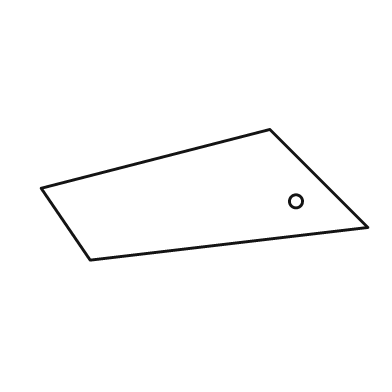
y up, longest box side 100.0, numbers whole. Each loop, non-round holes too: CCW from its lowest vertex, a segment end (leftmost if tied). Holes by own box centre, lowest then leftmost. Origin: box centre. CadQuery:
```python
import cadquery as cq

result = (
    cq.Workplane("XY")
    .moveTo(-35.0, -20.0)
    .lineTo(50.0, -10.0)
    .lineTo(20.0, 20.0)
    .lineTo(-50.0, 2.0)
    .close()
    .moveTo(28.0, -2.0)
    .circle(2.0)
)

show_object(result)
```